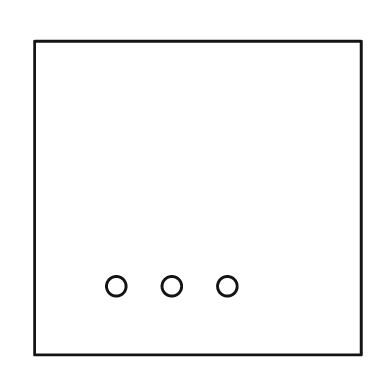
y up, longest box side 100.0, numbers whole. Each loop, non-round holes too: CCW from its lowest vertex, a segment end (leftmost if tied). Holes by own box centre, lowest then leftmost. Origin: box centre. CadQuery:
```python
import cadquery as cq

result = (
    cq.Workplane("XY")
    .moveTo(-50.0, -48.0)
    .lineTo(50.0, -48.0)
    .lineTo(50.0, 48.0)
    .lineTo(-50.0, 48.0)
    .close()
    .moveTo(-25.0, -27.0)
    .circle(3.0)
    .moveTo(-8.0, -27.0)
    .circle(3.0)
    .moveTo(9.0, -27.0)
    .circle(3.0)
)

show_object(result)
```